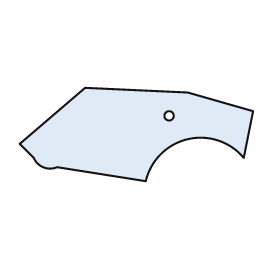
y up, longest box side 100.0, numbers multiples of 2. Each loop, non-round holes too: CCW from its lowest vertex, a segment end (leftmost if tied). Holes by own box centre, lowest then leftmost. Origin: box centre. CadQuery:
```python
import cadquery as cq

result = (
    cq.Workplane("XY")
    .moveTo(4.0, -20.0)
    .threePointArc((22.0, -2.0), (46.0, -10.0))
    .lineTo(50.0, 10.0)
    .lineTo(22.0, 18.0)
    .lineTo(-22.0, 20.0)
    .lineTo(-50.0, -4.0)
    .lineTo(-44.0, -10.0)
    .threePointArc((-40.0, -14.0), (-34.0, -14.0))
    .close()
    .moveTo(14.0, 8.0)
    .circle(2.0)
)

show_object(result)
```